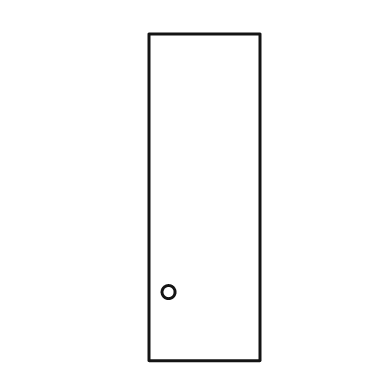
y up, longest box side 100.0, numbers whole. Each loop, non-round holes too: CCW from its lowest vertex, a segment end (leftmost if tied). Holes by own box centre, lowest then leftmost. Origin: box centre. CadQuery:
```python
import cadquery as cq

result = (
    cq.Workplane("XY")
    .moveTo(-17.0, -50.0)
    .lineTo(17.0, -50.0)
    .lineTo(17.0, 50.0)
    .lineTo(-17.0, 50.0)
    .close()
    .moveTo(-11.0, -29.0)
    .circle(2.0)
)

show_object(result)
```